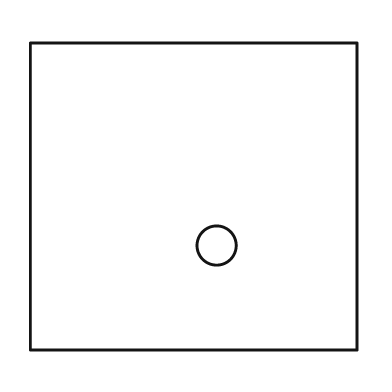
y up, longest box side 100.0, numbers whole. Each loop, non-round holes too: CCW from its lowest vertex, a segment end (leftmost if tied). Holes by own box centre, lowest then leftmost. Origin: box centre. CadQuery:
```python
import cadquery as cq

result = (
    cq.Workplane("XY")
    .moveTo(-50.0, -47.0)
    .lineTo(50.0, -47.0)
    .lineTo(50.0, 47.0)
    .lineTo(-50.0, 47.0)
    .close()
    .moveTo(7.0, -15.0)
    .circle(6.0)
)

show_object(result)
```